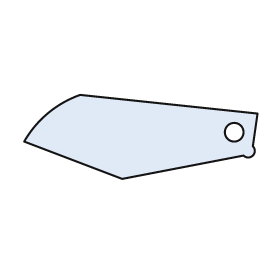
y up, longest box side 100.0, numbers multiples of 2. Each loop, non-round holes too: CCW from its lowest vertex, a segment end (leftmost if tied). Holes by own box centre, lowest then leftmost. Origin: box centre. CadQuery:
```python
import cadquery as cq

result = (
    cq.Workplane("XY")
    .moveTo(-8.0, -18.0)
    .lineTo(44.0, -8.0)
    .threePointArc((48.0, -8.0), (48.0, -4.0))
    .lineTo(50.0, 10.0)
    .lineTo(-26.0, 18.0)
    .threePointArc((-40.0, 10.0), (-50.0, -2.0))
    .close()
    .moveTo(40.0, 2.0)
    .circle(4.0)
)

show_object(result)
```